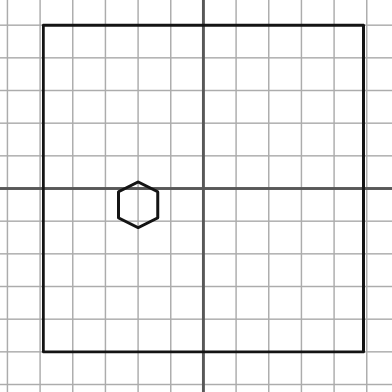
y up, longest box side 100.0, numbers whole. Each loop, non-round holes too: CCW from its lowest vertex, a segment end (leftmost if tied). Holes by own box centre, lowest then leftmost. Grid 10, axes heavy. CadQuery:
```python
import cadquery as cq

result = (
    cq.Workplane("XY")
    .moveTo(-49.0, -50.0)
    .lineTo(49.0, -50.0)
    .lineTo(49.0, 50.0)
    .lineTo(-49.0, 50.0)
    .close()
    .moveTo(-20.0, -12.0)
    .lineTo(-14.0, -9.0)
    .lineTo(-14.0, -1.0)
    .lineTo(-20.0, 2.0)
    .lineTo(-26.0, -1.0)
    .lineTo(-26.0, -9.0)
    .close()
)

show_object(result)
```